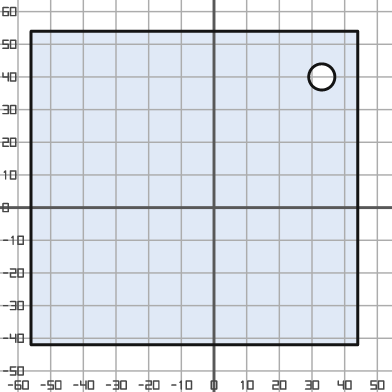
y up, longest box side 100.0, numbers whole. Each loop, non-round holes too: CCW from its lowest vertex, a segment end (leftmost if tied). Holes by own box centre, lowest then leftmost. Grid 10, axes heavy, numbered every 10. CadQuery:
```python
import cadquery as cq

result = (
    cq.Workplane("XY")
    .moveTo(-56.0, -42.0)
    .lineTo(44.0, -42.0)
    .lineTo(44.0, 54.0)
    .lineTo(-56.0, 54.0)
    .close()
    .moveTo(33.0, 40.0)
    .circle(4.0)
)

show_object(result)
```